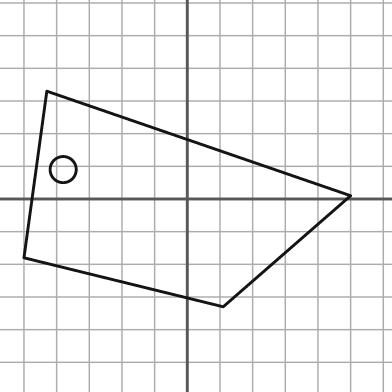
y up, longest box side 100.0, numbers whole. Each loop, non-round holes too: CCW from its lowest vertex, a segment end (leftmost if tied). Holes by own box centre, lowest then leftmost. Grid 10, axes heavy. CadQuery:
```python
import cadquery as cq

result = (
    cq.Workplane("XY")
    .moveTo(11.0, -33.0)
    .lineTo(50.0, 1.0)
    .lineTo(-43.0, 33.0)
    .lineTo(-50.0, -18.0)
    .close()
    .moveTo(-38.0, 9.0)
    .circle(4.0)
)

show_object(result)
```